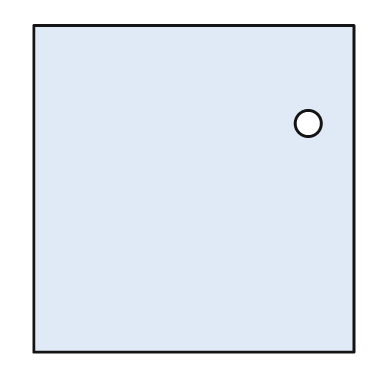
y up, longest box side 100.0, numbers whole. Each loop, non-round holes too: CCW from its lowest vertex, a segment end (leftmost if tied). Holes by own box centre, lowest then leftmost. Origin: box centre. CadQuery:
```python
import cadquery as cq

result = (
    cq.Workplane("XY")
    .moveTo(-49.0, -50.0)
    .lineTo(49.0, -50.0)
    .lineTo(49.0, 50.0)
    .lineTo(-49.0, 50.0)
    .close()
    .moveTo(35.0, 20.0)
    .circle(4.0)
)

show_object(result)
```